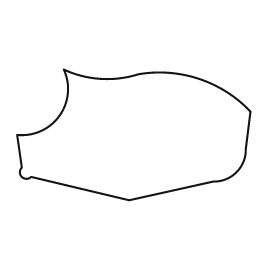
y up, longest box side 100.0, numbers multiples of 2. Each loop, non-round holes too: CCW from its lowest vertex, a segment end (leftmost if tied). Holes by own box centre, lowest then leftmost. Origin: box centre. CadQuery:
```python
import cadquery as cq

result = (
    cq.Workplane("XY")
    .moveTo(-2.0, -28.0)
    .lineTo(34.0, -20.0)
    .threePointArc((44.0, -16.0), (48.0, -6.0))
    .lineTo(50.0, 10.0)
    .threePointArc((28.0, 24.0), (2.0, 26.0))
    .threePointArc((-14.0, 24.0), (-30.0, 28.0))
    .threePointArc((-32.0, 8.0), (-50.0, 0.0))
    .lineTo(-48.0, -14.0)
    .threePointArc((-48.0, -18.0), (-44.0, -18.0))
    .close()
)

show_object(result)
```